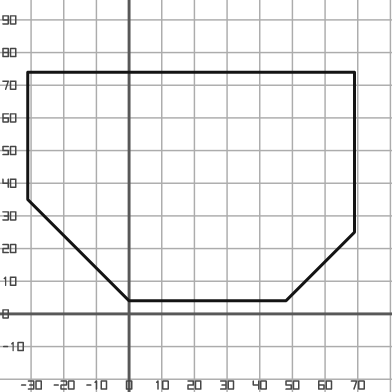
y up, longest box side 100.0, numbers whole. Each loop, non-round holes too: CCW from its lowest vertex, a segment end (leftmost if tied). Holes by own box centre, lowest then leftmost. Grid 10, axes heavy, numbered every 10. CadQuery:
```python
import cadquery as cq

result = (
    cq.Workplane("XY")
    .moveTo(0.0, 4.0)
    .lineTo(48.0, 4.0)
    .lineTo(69.0, 25.0)
    .lineTo(69.0, 74.0)
    .lineTo(-31.0, 74.0)
    .lineTo(-31.0, 35.0)
    .close()
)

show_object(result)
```